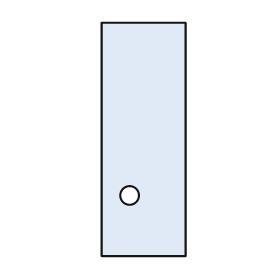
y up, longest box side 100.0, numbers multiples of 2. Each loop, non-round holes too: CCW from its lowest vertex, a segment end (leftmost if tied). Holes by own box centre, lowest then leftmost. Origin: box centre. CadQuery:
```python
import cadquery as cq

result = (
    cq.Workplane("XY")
    .moveTo(-18.0, -50.0)
    .lineTo(18.0, -50.0)
    .lineTo(18.0, 50.0)
    .lineTo(-18.0, 50.0)
    .close()
    .moveTo(-6.0, -24.0)
    .circle(4.0)
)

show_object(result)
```